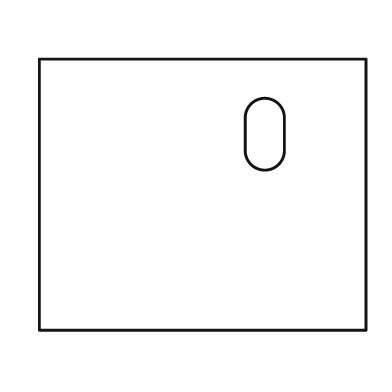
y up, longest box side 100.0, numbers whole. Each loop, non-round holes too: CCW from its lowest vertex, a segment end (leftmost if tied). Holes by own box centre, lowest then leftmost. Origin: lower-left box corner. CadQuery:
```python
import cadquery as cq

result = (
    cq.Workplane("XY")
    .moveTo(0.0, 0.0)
    .lineTo(100.0, 0.0)
    .lineTo(100.0, 83.0)
    .lineTo(0.0, 83.0)
    .close()
    .moveTo(63.0, 55.0)
    .threePointArc((69.0, 49.0), (75.0, 55.0))
    .lineTo(75.0, 65.0)
    .threePointArc((69.0, 71.0), (63.0, 65.0))
    .close()
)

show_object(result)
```